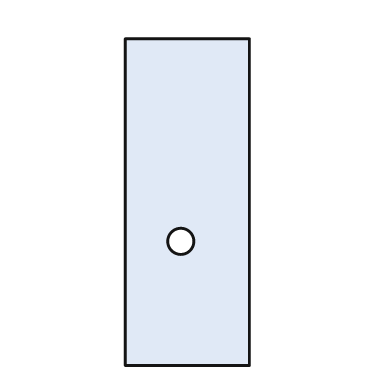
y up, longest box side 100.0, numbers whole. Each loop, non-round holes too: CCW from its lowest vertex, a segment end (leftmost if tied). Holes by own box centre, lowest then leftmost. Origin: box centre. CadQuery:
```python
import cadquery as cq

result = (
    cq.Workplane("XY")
    .moveTo(-19.0, -50.0)
    .lineTo(19.0, -50.0)
    .lineTo(19.0, 50.0)
    .lineTo(-19.0, 50.0)
    .close()
    .moveTo(-2.0, -12.0)
    .circle(4.0)
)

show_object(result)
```